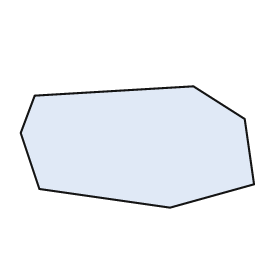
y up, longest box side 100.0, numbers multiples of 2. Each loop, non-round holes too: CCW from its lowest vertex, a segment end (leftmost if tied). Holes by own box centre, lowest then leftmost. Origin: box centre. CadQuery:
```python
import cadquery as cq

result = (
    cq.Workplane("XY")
    .moveTo(14.0, -26.0)
    .lineTo(50.0, -16.0)
    .lineTo(46.0, 12.0)
    .lineTo(24.0, 26.0)
    .lineTo(-44.0, 22.0)
    .lineTo(-50.0, 6.0)
    .lineTo(-42.0, -18.0)
    .close()
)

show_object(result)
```